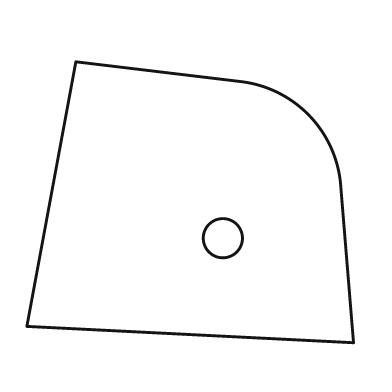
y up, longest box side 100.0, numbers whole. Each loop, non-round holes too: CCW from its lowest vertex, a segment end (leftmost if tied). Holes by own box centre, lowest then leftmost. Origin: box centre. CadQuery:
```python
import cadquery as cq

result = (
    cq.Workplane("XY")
    .moveTo(50.0, -43.0)
    .lineTo(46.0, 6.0)
    .threePointArc((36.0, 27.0), (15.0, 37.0))
    .lineTo(-35.0, 43.0)
    .lineTo(-50.0, -38.0)
    .close()
    .moveTo(10.0, -11.0)
    .circle(6.0)
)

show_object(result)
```